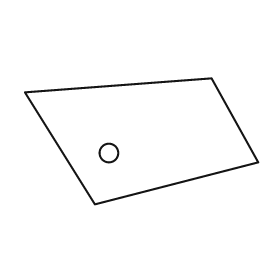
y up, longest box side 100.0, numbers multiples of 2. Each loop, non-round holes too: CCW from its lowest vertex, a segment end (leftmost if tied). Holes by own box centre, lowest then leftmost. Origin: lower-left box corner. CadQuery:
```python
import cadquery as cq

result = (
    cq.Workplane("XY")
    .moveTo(30.0, 0.0)
    .lineTo(100.0, 18.0)
    .lineTo(80.0, 54.0)
    .lineTo(0.0, 48.0)
    .close()
    .moveTo(36.0, 22.0)
    .circle(4.0)
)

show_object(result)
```